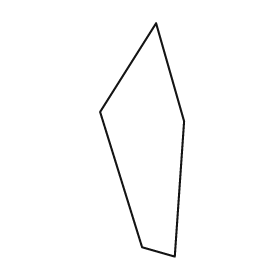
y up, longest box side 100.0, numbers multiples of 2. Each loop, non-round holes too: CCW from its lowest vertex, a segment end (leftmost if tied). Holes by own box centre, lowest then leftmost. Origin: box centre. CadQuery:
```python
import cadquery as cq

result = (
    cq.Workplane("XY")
    .moveTo(14.0, -50.0)
    .lineTo(18.0, 8.0)
    .lineTo(6.0, 50.0)
    .lineTo(-18.0, 12.0)
    .lineTo(0.0, -46.0)
    .close()
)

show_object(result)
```